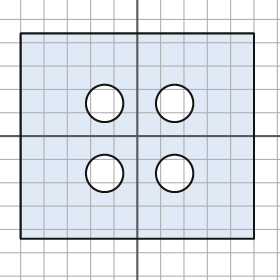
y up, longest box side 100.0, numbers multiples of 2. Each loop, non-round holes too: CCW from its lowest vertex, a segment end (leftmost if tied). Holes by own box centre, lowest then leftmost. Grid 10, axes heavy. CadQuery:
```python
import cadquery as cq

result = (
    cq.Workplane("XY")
    .moveTo(-50.0, -44.0)
    .lineTo(50.0, -44.0)
    .lineTo(50.0, 44.0)
    .lineTo(-50.0, 44.0)
    .close()
    .moveTo(-14.0, -16.0)
    .circle(8.0)
    .moveTo(16.0, -16.0)
    .circle(8.0)
    .moveTo(-14.0, 14.0)
    .circle(8.0)
    .moveTo(16.0, 14.0)
    .circle(8.0)
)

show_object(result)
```